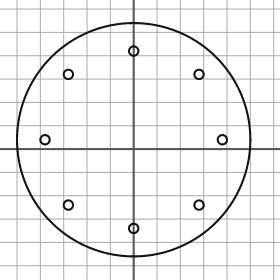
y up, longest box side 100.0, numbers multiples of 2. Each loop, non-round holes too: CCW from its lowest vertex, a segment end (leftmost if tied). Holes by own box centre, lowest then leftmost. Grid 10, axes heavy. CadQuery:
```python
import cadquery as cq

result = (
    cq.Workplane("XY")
    .moveTo(0.0, 4.0)
    .circle(50.0)
    .moveTo(0.0, -34.0)
    .circle(2.0)
    .moveTo(-28.0, -24.0)
    .circle(2.0)
    .moveTo(28.0, -24.0)
    .circle(2.0)
    .moveTo(-38.0, 4.0)
    .circle(2.0)
    .moveTo(38.0, 4.0)
    .circle(2.0)
    .moveTo(-28.0, 32.0)
    .circle(2.0)
    .moveTo(28.0, 32.0)
    .circle(2.0)
    .moveTo(0.0, 42.0)
    .circle(2.0)
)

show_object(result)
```